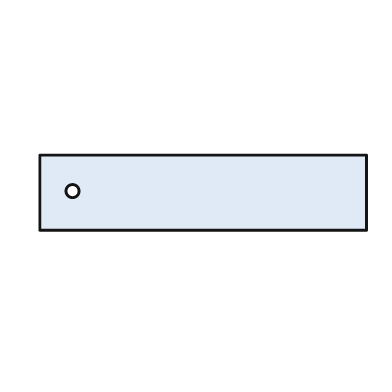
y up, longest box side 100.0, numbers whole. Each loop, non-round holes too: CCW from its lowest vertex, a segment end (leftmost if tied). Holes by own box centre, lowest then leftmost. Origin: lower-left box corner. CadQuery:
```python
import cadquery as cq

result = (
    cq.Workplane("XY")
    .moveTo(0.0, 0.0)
    .lineTo(100.0, 0.0)
    .lineTo(100.0, 23.0)
    .lineTo(0.0, 23.0)
    .close()
    .moveTo(10.0, 12.0)
    .circle(2.0)
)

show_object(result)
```